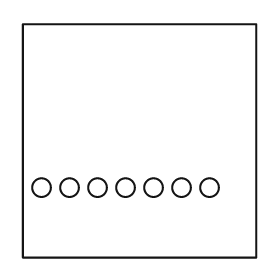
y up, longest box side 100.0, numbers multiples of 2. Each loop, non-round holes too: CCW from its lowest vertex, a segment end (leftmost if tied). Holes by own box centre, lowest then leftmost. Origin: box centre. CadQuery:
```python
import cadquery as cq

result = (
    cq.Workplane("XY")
    .moveTo(-50.0, -50.0)
    .lineTo(50.0, -50.0)
    .lineTo(50.0, 50.0)
    .lineTo(-50.0, 50.0)
    .close()
    .moveTo(-42.0, -20.0)
    .circle(4.0)
    .moveTo(-30.0, -20.0)
    .circle(4.0)
    .moveTo(-18.0, -20.0)
    .circle(4.0)
    .moveTo(-6.0, -20.0)
    .circle(4.0)
    .moveTo(6.0, -20.0)
    .circle(4.0)
    .moveTo(18.0, -20.0)
    .circle(4.0)
    .moveTo(30.0, -20.0)
    .circle(4.0)
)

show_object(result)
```